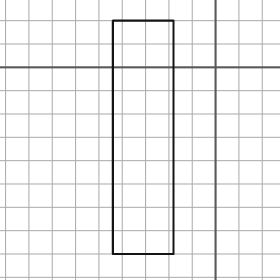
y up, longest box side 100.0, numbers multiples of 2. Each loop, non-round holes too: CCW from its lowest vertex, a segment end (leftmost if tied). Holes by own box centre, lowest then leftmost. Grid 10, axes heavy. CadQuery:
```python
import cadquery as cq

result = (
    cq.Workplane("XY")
    .moveTo(-44.0, -80.0)
    .lineTo(-18.0, -80.0)
    .lineTo(-18.0, 20.0)
    .lineTo(-44.0, 20.0)
    .close()
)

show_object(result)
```